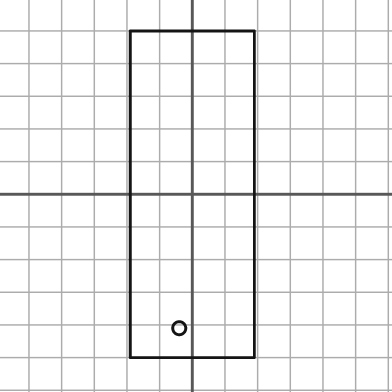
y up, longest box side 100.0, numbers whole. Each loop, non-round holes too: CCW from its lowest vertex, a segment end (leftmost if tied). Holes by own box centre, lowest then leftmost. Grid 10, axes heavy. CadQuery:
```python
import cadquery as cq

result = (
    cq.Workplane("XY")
    .moveTo(-19.0, -50.0)
    .lineTo(19.0, -50.0)
    .lineTo(19.0, 50.0)
    .lineTo(-19.0, 50.0)
    .close()
    .moveTo(-4.0, -41.0)
    .circle(2.0)
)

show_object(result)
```